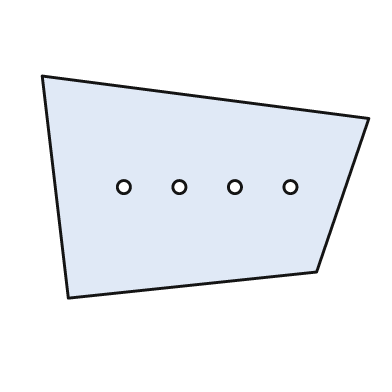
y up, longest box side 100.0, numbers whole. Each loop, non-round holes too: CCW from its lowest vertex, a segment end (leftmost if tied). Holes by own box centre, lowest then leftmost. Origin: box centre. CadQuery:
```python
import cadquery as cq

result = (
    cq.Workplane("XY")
    .moveTo(-42.0, -34.0)
    .lineTo(34.0, -26.0)
    .lineTo(50.0, 21.0)
    .lineTo(-50.0, 34.0)
    .close()
    .moveTo(-25.0, 0.0)
    .circle(2.0)
    .moveTo(-8.0, 0.0)
    .circle(2.0)
    .moveTo(9.0, 0.0)
    .circle(2.0)
    .moveTo(26.0, 0.0)
    .circle(2.0)
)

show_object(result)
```